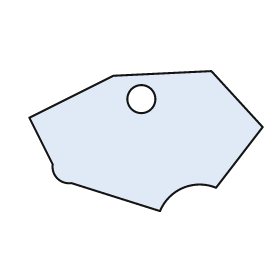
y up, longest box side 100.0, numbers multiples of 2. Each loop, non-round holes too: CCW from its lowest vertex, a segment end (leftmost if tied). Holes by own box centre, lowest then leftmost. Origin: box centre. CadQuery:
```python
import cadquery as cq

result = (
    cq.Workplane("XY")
    .moveTo(6.0, -30.0)
    .threePointArc((16.0, -20.0), (30.0, -20.0))
    .lineTo(50.0, 6.0)
    .lineTo(28.0, 30.0)
    .lineTo(-14.0, 28.0)
    .lineTo(-50.0, 10.0)
    .lineTo(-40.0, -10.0)
    .threePointArc((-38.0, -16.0), (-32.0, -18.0))
    .close()
    .moveTo(-2.0, 18.0)
    .circle(6.0)
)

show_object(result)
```